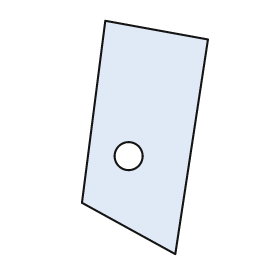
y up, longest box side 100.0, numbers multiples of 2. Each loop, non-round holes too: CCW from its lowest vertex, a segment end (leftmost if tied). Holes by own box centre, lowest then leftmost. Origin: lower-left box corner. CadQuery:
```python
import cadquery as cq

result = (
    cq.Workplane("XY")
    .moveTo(40.0, 0.0)
    .lineTo(54.0, 92.0)
    .lineTo(10.0, 100.0)
    .lineTo(0.0, 22.0)
    .close()
    .moveTo(20.0, 42.0)
    .circle(6.0)
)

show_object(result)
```